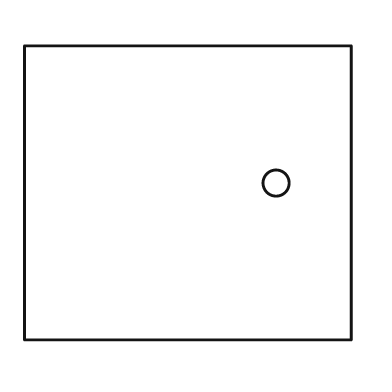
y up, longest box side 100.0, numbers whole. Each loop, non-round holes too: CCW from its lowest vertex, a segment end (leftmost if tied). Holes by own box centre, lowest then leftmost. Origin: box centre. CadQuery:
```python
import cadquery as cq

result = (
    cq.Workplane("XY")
    .moveTo(-50.0, -45.0)
    .lineTo(50.0, -45.0)
    .lineTo(50.0, 45.0)
    .lineTo(-50.0, 45.0)
    .close()
    .moveTo(27.0, 3.0)
    .circle(4.0)
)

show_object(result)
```